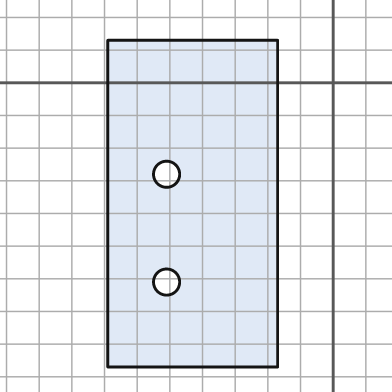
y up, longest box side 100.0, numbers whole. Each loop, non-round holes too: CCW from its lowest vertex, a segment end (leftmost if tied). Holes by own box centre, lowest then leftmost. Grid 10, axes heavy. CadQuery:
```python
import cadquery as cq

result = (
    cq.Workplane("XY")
    .moveTo(-69.0, -87.0)
    .lineTo(-17.0, -87.0)
    .lineTo(-17.0, 13.0)
    .lineTo(-69.0, 13.0)
    .close()
    .moveTo(-51.0, -61.0)
    .circle(4.0)
    .moveTo(-51.0, -28.0)
    .circle(4.0)
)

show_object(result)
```